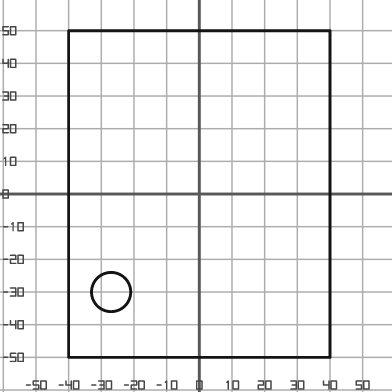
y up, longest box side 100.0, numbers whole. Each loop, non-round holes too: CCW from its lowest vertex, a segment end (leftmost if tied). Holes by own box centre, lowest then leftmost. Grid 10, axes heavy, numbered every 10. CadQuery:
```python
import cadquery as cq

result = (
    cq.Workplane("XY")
    .moveTo(-40.0, -50.0)
    .lineTo(40.0, -50.0)
    .lineTo(40.0, 50.0)
    .lineTo(-40.0, 50.0)
    .close()
    .moveTo(-27.0, -30.0)
    .circle(6.0)
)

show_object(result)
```